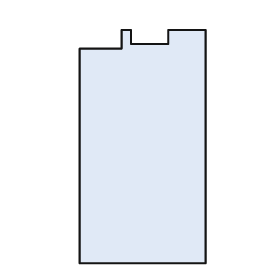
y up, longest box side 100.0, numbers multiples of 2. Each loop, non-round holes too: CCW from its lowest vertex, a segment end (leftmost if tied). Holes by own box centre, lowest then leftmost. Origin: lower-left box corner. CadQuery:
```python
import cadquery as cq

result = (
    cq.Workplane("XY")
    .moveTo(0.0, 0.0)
    .lineTo(54.0, 0.0)
    .lineTo(54.0, 100.0)
    .lineTo(38.0, 100.0)
    .lineTo(38.0, 94.0)
    .lineTo(22.0, 94.0)
    .lineTo(22.0, 100.0)
    .lineTo(18.0, 100.0)
    .lineTo(18.0, 92.0)
    .lineTo(0.0, 92.0)
    .close()
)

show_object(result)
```